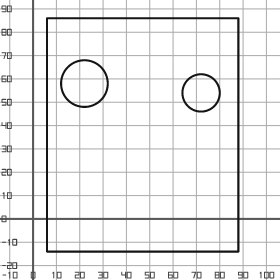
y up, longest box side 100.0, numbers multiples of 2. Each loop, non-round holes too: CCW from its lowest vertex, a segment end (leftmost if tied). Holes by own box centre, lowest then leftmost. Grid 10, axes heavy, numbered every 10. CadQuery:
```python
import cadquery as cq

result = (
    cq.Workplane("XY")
    .moveTo(6.0, -14.0)
    .lineTo(88.0, -14.0)
    .lineTo(88.0, 86.0)
    .lineTo(6.0, 86.0)
    .close()
    .moveTo(72.0, 54.0)
    .circle(8.0)
    .moveTo(22.0, 58.0)
    .circle(10.0)
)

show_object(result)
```